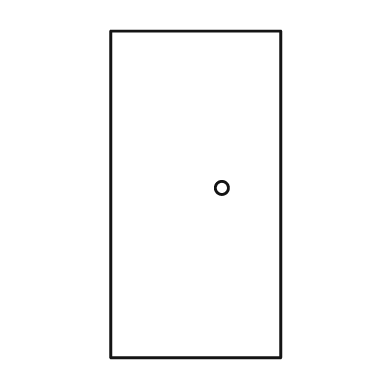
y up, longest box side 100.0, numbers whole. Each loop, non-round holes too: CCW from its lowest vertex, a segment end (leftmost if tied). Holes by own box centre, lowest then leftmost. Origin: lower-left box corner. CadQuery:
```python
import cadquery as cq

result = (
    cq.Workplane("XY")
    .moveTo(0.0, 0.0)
    .lineTo(52.0, 0.0)
    .lineTo(52.0, 100.0)
    .lineTo(0.0, 100.0)
    .close()
    .moveTo(34.0, 52.0)
    .circle(2.0)
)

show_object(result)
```